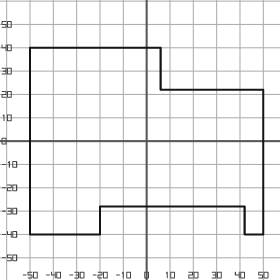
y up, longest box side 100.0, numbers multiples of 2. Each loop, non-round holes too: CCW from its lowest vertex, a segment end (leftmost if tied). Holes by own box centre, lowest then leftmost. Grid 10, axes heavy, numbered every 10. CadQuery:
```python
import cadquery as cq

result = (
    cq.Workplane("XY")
    .moveTo(-50.0, -40.0)
    .lineTo(-20.0, -40.0)
    .lineTo(-20.0, -28.0)
    .lineTo(42.0, -28.0)
    .lineTo(42.0, -40.0)
    .lineTo(50.0, -40.0)
    .lineTo(50.0, 22.0)
    .lineTo(6.0, 22.0)
    .lineTo(6.0, 40.0)
    .lineTo(-50.0, 40.0)
    .close()
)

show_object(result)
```